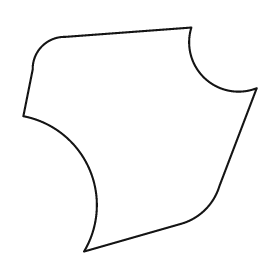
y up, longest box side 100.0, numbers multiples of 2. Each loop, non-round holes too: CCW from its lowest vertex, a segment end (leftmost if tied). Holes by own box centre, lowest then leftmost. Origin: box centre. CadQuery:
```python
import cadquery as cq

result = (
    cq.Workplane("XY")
    .moveTo(-24.0, -48.0)
    .lineTo(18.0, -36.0)
    .threePointArc((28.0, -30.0), (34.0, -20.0))
    .lineTo(50.0, 22.0)
    .threePointArc((28.0, 26.0), (22.0, 48.0))
    .lineTo(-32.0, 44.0)
    .threePointArc((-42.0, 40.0), (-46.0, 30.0))
    .lineTo(-50.0, 10.0)
    .threePointArc((-22.0, -12.0), (-24.0, -48.0))
    .close()
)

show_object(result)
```